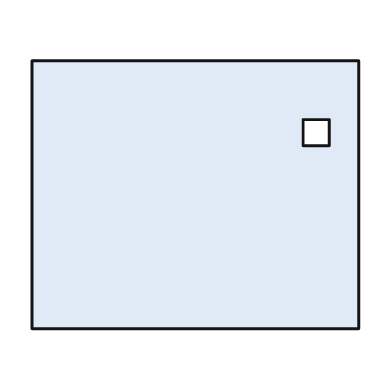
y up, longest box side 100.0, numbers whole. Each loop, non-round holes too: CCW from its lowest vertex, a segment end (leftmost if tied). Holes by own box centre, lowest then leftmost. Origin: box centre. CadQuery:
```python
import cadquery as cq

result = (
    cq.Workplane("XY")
    .moveTo(-50.0, -41.0)
    .lineTo(50.0, -41.0)
    .lineTo(50.0, 41.0)
    .lineTo(-50.0, 41.0)
    .close()
    .moveTo(33.0, 15.0)
    .lineTo(41.0, 15.0)
    .lineTo(41.0, 23.0)
    .lineTo(33.0, 23.0)
    .close()
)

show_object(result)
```